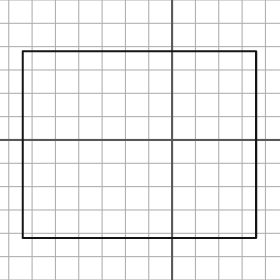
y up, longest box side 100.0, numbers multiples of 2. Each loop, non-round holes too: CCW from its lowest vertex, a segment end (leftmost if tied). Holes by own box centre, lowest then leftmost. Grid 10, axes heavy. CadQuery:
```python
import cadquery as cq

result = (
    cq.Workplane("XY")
    .moveTo(-64.0, -42.0)
    .lineTo(36.0, -42.0)
    .lineTo(36.0, 38.0)
    .lineTo(-64.0, 38.0)
    .close()
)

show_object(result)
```